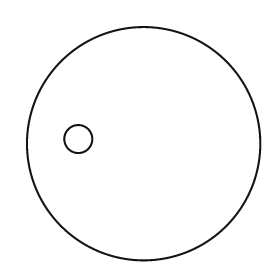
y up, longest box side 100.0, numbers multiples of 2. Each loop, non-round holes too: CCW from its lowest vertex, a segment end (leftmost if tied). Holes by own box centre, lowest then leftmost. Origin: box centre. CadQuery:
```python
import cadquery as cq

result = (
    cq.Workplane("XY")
    .moveTo(0.0, 0.0)
    .circle(50.0)
    .moveTo(-28.0, 2.0)
    .circle(6.0)
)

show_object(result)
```